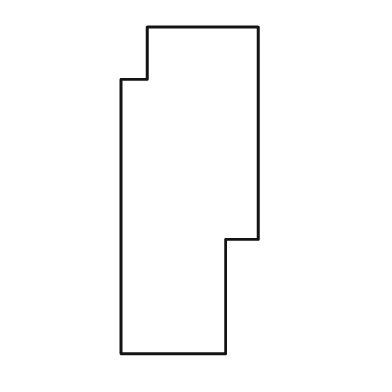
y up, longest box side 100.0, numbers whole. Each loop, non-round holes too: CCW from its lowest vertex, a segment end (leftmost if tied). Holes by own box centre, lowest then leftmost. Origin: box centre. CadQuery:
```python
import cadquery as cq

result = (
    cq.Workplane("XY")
    .moveTo(-21.0, -50.0)
    .lineTo(11.0, -50.0)
    .lineTo(11.0, -15.0)
    .lineTo(21.0, -15.0)
    .lineTo(21.0, 50.0)
    .lineTo(-13.0, 50.0)
    .lineTo(-13.0, 34.0)
    .lineTo(-21.0, 34.0)
    .close()
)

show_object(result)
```